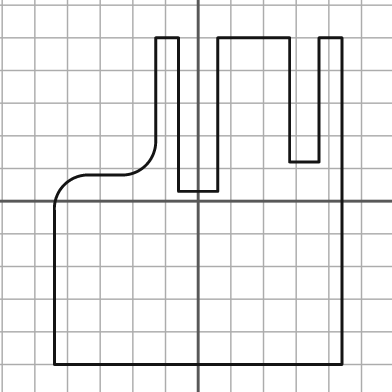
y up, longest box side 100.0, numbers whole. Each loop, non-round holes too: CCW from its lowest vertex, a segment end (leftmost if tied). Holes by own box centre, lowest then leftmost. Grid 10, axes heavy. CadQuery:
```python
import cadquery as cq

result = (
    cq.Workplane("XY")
    .moveTo(-44.0, -50.0)
    .lineTo(44.0, -50.0)
    .lineTo(44.0, 50.0)
    .lineTo(37.0, 50.0)
    .lineTo(37.0, 12.0)
    .lineTo(28.0, 12.0)
    .lineTo(28.0, 50.0)
    .lineTo(6.0, 50.0)
    .lineTo(6.0, 3.0)
    .lineTo(-6.0, 3.0)
    .lineTo(-6.0, 50.0)
    .lineTo(-13.0, 50.0)
    .lineTo(-13.0, 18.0)
    .threePointArc((-16.0, 11.0), (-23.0, 8.0))
    .lineTo(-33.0, 8.0)
    .threePointArc((-41.0, 5.0), (-44.0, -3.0))
    .close()
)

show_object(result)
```